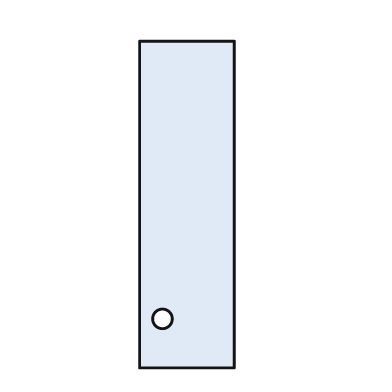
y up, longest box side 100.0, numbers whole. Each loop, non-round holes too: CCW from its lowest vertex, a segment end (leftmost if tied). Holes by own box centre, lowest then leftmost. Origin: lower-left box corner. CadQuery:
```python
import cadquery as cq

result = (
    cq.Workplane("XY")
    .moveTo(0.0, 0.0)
    .lineTo(29.0, 0.0)
    .lineTo(29.0, 100.0)
    .lineTo(0.0, 100.0)
    .close()
    .moveTo(7.0, 15.0)
    .circle(3.0)
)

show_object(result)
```